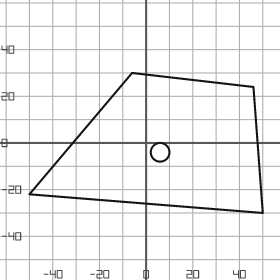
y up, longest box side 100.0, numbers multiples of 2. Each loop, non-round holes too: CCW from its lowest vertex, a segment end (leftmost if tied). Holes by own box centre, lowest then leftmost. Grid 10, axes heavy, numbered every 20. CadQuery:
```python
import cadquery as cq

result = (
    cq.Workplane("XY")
    .moveTo(50.0, -30.0)
    .lineTo(46.0, 24.0)
    .lineTo(-6.0, 30.0)
    .lineTo(-50.0, -22.0)
    .close()
    .moveTo(6.0, -4.0)
    .circle(4.0)
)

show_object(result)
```